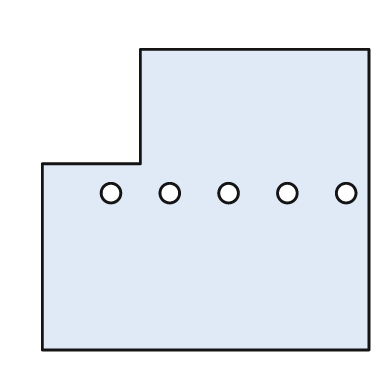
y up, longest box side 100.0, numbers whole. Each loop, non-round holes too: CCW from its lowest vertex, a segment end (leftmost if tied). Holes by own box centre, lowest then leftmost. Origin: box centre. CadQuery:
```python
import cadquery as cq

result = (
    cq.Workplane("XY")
    .moveTo(-50.0, -46.0)
    .lineTo(50.0, -46.0)
    .lineTo(50.0, 46.0)
    .lineTo(-20.0, 46.0)
    .lineTo(-20.0, 11.0)
    .lineTo(-50.0, 11.0)
    .close()
    .moveTo(-29.0, 2.0)
    .circle(3.0)
    .moveTo(-11.0, 2.0)
    .circle(3.0)
    .moveTo(7.0, 2.0)
    .circle(3.0)
    .moveTo(25.0, 2.0)
    .circle(3.0)
    .moveTo(43.0, 2.0)
    .circle(3.0)
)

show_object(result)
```